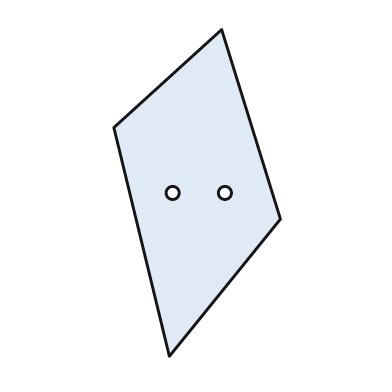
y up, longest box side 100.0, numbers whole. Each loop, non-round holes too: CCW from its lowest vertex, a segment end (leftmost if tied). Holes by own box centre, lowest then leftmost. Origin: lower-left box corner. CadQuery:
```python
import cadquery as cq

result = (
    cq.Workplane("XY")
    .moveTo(17.0, 0.0)
    .lineTo(51.0, 42.0)
    .lineTo(33.0, 100.0)
    .lineTo(0.0, 70.0)
    .close()
    .moveTo(18.0, 50.0)
    .circle(2.0)
    .moveTo(34.0, 50.0)
    .circle(2.0)
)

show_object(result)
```